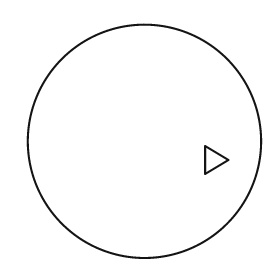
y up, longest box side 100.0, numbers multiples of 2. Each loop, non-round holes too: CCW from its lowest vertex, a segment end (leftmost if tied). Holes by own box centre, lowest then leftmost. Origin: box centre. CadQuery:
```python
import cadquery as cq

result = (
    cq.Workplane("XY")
    .moveTo(0.0, 0.0)
    .circle(50.0)
    .moveTo(26.0, -14.0)
    .lineTo(36.0, -8.0)
    .lineTo(26.0, -2.0)
    .close()
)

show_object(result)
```